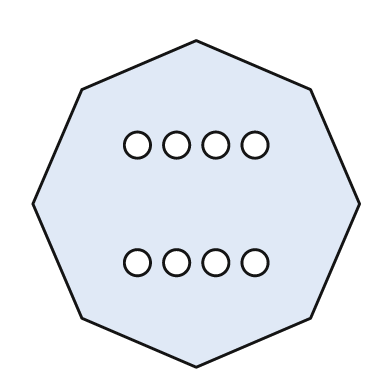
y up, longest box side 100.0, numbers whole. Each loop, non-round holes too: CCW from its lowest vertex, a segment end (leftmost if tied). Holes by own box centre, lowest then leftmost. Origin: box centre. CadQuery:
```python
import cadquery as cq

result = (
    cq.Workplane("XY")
    .moveTo(0.0, -50.0)
    .lineTo(35.0, -35.0)
    .lineTo(50.0, 0.0)
    .lineTo(35.0, 35.0)
    .lineTo(0.0, 50.0)
    .lineTo(-35.0, 35.0)
    .lineTo(-50.0, 0.0)
    .lineTo(-35.0, -35.0)
    .close()
    .moveTo(-18.0, -18.0)
    .circle(4.0)
    .moveTo(-6.0, -18.0)
    .circle(4.0)
    .moveTo(6.0, -18.0)
    .circle(4.0)
    .moveTo(18.0, -18.0)
    .circle(4.0)
    .moveTo(-18.0, 18.0)
    .circle(4.0)
    .moveTo(-6.0, 18.0)
    .circle(4.0)
    .moveTo(6.0, 18.0)
    .circle(4.0)
    .moveTo(18.0, 18.0)
    .circle(4.0)
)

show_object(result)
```